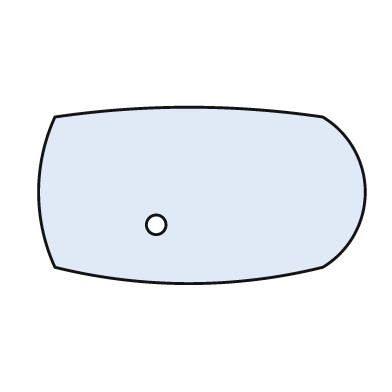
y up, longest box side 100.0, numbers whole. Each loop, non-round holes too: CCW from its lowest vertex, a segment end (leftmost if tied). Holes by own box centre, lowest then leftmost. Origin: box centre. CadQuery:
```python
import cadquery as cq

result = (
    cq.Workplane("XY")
    .moveTo(-45.0, -22.0)
    .threePointArc((-4.0, -27.0), (37.0, -22.0))
    .threePointArc((50.0, 1.0), (37.0, 24.0))
    .threePointArc((-4.0, 27.0), (-45.0, 24.0))
    .threePointArc((-50.0, 1.0), (-45.0, -22.0))
    .close()
    .moveTo(-14.0, -9.0)
    .circle(3.0)
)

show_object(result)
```